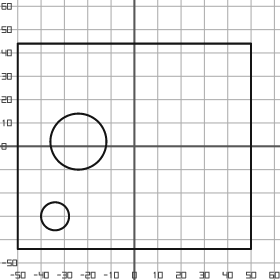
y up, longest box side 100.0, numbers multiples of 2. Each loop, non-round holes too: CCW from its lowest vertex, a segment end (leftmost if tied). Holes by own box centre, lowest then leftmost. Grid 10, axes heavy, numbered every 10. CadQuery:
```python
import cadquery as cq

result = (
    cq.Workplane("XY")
    .moveTo(-50.0, -44.0)
    .lineTo(50.0, -44.0)
    .lineTo(50.0, 44.0)
    .lineTo(-50.0, 44.0)
    .close()
    .moveTo(-34.0, -30.0)
    .circle(6.0)
    .moveTo(-24.0, 2.0)
    .circle(12.0)
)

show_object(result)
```